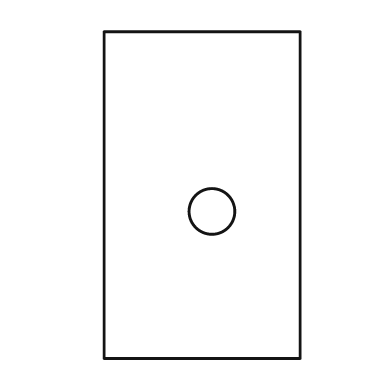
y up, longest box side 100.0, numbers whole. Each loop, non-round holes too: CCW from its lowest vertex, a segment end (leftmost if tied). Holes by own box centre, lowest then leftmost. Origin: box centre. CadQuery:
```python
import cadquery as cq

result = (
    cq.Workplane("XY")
    .moveTo(-30.0, -50.0)
    .lineTo(30.0, -50.0)
    .lineTo(30.0, 50.0)
    .lineTo(-30.0, 50.0)
    .close()
    .moveTo(3.0, -5.0)
    .circle(7.0)
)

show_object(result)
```